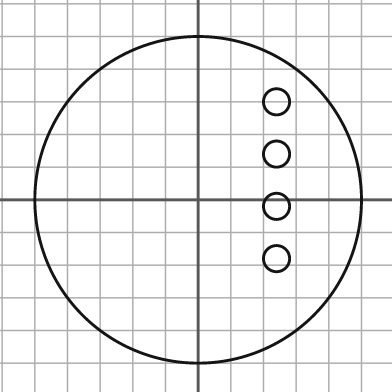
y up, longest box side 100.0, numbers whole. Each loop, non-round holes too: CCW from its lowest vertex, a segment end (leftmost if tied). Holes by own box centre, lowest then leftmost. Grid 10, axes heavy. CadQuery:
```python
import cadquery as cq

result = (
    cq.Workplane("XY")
    .moveTo(0.0, 0.0)
    .circle(50.0)
    .moveTo(24.0, -18.0)
    .circle(4.0)
    .moveTo(24.0, -2.0)
    .circle(4.0)
    .moveTo(24.0, 14.0)
    .circle(4.0)
    .moveTo(24.0, 30.0)
    .circle(4.0)
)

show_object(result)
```